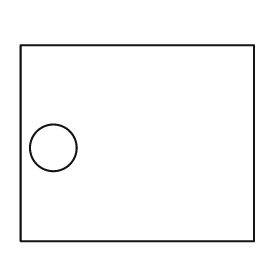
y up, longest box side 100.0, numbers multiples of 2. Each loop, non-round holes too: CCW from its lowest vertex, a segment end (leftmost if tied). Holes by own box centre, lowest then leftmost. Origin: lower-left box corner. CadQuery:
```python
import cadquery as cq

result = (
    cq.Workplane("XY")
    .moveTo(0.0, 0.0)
    .lineTo(100.0, 0.0)
    .lineTo(100.0, 84.0)
    .lineTo(0.0, 84.0)
    .close()
    .moveTo(14.0, 40.0)
    .circle(10.0)
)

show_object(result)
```